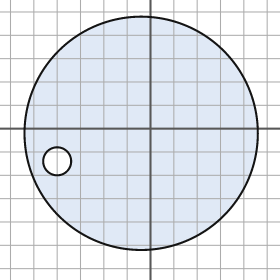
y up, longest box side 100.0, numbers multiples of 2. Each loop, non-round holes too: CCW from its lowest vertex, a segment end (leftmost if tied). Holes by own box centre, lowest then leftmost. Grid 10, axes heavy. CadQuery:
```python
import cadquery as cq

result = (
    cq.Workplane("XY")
    .moveTo(-4.0, -2.0)
    .circle(50.0)
    .moveTo(-40.0, -14.0)
    .circle(6.0)
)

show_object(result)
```